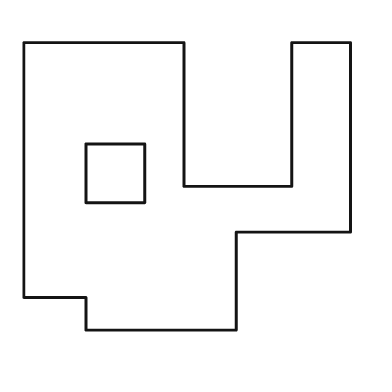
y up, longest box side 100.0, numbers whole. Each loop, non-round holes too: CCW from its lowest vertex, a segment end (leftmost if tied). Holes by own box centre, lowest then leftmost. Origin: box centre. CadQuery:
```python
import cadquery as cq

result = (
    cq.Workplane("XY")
    .moveTo(-31.0, -44.0)
    .lineTo(15.0, -44.0)
    .lineTo(15.0, -14.0)
    .lineTo(50.0, -14.0)
    .lineTo(50.0, 44.0)
    .lineTo(32.0, 44.0)
    .lineTo(32.0, 0.0)
    .lineTo(-1.0, 0.0)
    .lineTo(-1.0, 44.0)
    .lineTo(-50.0, 44.0)
    .lineTo(-50.0, -34.0)
    .lineTo(-31.0, -34.0)
    .close()
    .moveTo(-31.0, -5.0)
    .lineTo(-13.0, -5.0)
    .lineTo(-13.0, 13.0)
    .lineTo(-31.0, 13.0)
    .close()
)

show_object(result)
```